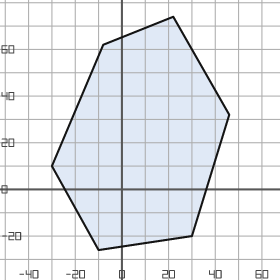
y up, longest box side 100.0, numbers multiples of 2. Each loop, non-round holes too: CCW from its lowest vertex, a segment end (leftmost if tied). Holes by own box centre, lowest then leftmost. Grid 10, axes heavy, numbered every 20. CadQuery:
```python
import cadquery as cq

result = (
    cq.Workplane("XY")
    .moveTo(-10.0, -26.0)
    .lineTo(30.0, -20.0)
    .lineTo(46.0, 32.0)
    .lineTo(22.0, 74.0)
    .lineTo(-8.0, 62.0)
    .lineTo(-30.0, 10.0)
    .close()
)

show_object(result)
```